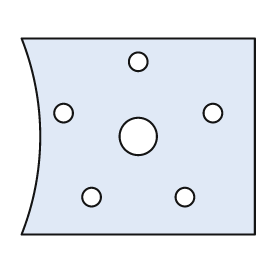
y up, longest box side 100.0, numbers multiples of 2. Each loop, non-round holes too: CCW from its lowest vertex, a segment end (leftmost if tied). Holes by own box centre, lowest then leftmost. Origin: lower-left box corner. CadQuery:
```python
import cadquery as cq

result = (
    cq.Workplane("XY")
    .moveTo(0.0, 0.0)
    .lineTo(100.0, 0.0)
    .lineTo(100.0, 84.0)
    .lineTo(0.0, 84.0)
    .threePointArc((8.0, 42.0), (0.0, 0.0))
    .close()
    .moveTo(30.0, 16.0)
    .circle(4.0)
    .moveTo(70.0, 16.0)
    .circle(4.0)
    .moveTo(50.0, 42.0)
    .circle(8.0)
    .moveTo(18.0, 52.0)
    .circle(4.0)
    .moveTo(82.0, 52.0)
    .circle(4.0)
    .moveTo(50.0, 74.0)
    .circle(4.0)
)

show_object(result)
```